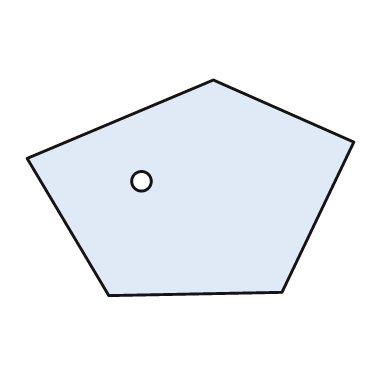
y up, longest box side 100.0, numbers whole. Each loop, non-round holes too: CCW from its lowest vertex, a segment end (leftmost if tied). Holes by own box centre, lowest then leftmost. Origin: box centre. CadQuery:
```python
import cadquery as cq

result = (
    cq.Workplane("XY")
    .moveTo(-25.0, -33.0)
    .lineTo(28.0, -32.0)
    .lineTo(50.0, 14.0)
    .lineTo(7.0, 33.0)
    .lineTo(-50.0, 9.0)
    .close()
    .moveTo(-15.0, 2.0)
    .circle(3.0)
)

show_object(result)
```